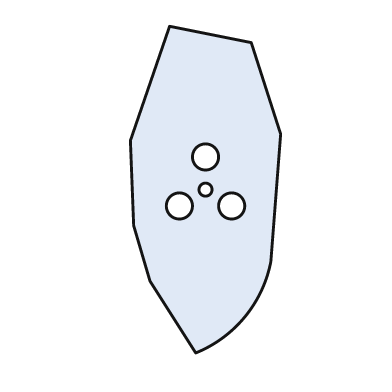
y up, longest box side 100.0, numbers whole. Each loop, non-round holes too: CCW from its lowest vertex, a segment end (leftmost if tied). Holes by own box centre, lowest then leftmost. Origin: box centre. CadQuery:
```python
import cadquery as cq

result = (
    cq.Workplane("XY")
    .moveTo(-3.0, -50.0)
    .threePointArc((12.0, -39.0), (20.0, -22.0))
    .lineTo(23.0, 17.0)
    .lineTo(14.0, 45.0)
    .lineTo(-11.0, 50.0)
    .lineTo(-23.0, 15.0)
    .lineTo(-22.0, -11.0)
    .lineTo(-17.0, -28.0)
    .close()
    .moveTo(-8.0, -5.0)
    .circle(4.0)
    .moveTo(8.0, -5.0)
    .circle(4.0)
    .moveTo(0.0, 0.0)
    .circle(2.0)
    .moveTo(0.0, 10.0)
    .circle(4.0)
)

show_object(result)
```